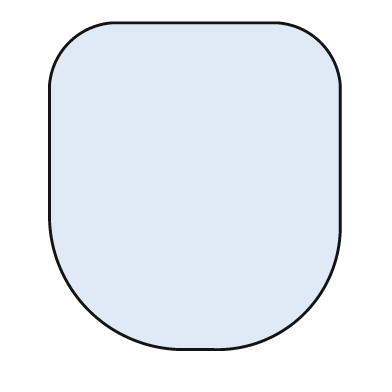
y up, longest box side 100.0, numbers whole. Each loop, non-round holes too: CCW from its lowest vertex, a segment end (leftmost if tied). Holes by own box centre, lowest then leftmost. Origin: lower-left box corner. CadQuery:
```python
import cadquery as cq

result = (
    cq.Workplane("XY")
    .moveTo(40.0, 0.0)
    .lineTo(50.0, 0.0)
    .threePointArc((78.0, 11.0), (89.0, 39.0))
    .lineTo(89.0, 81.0)
    .threePointArc((83.0, 94.0), (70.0, 100.0))
    .lineTo(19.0, 100.0)
    .threePointArc((6.0, 94.0), (0.0, 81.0))
    .lineTo(0.0, 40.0)
    .threePointArc((12.0, 12.0), (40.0, 0.0))
    .close()
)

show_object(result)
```